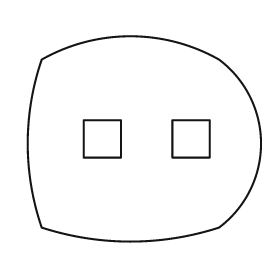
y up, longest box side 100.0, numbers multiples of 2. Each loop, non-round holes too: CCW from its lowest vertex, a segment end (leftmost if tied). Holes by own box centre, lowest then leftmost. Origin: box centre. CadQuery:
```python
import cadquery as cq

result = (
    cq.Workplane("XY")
    .moveTo(-44.0, -38.0)
    .threePointArc((-6.0, -44.0), (32.0, -38.0))
    .threePointArc((50.0, -2.0), (32.0, 34.0))
    .threePointArc((-6.0, 44.0), (-44.0, 34.0))
    .threePointArc((-50.0, -2.0), (-44.0, -38.0))
    .close()
    .moveTo(-26.0, -8.0)
    .lineTo(-10.0, -8.0)
    .lineTo(-10.0, 8.0)
    .lineTo(-26.0, 8.0)
    .close()
    .moveTo(12.0, -8.0)
    .lineTo(28.0, -8.0)
    .lineTo(28.0, 8.0)
    .lineTo(12.0, 8.0)
    .close()
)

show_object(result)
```